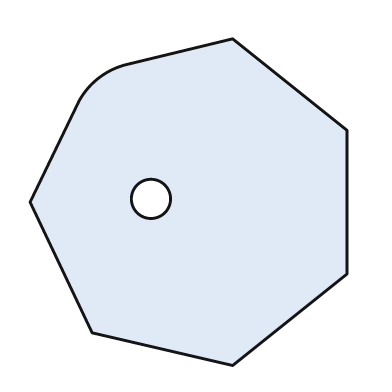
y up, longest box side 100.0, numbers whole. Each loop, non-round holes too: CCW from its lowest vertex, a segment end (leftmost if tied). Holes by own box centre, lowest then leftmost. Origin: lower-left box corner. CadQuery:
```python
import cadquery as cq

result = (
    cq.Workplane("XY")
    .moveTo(62.0, 0.0)
    .lineTo(97.0, 28.0)
    .lineTo(97.0, 72.0)
    .lineTo(62.0, 100.0)
    .lineTo(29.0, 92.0)
    .threePointArc((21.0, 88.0), (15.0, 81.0))
    .lineTo(0.0, 50.0)
    .lineTo(19.0, 10.0)
    .close()
    .moveTo(37.0, 51.0)
    .circle(6.0)
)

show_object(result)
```